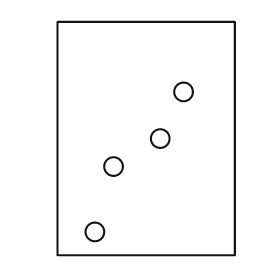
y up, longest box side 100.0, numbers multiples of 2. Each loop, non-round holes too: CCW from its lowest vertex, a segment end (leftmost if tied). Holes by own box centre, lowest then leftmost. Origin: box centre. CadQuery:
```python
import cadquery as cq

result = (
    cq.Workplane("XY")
    .moveTo(-38.0, -50.0)
    .lineTo(38.0, -50.0)
    .lineTo(38.0, 50.0)
    .lineTo(-38.0, 50.0)
    .close()
    .moveTo(-22.0, -40.0)
    .circle(4.0)
    .moveTo(-14.0, -12.0)
    .circle(4.0)
    .moveTo(6.0, 0.0)
    .circle(4.0)
    .moveTo(16.0, 20.0)
    .circle(4.0)
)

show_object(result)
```